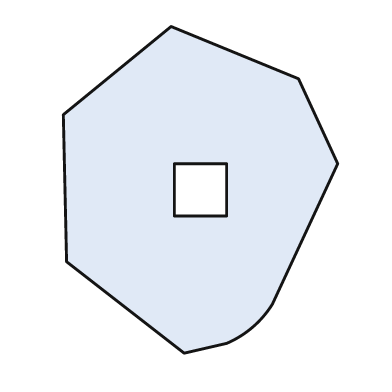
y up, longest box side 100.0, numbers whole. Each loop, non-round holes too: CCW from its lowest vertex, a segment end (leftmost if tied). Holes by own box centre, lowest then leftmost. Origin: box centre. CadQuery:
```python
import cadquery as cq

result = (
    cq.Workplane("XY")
    .moveTo(-5.0, -50.0)
    .lineTo(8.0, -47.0)
    .threePointArc((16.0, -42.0), (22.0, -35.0))
    .lineTo(42.0, 8.0)
    .lineTo(30.0, 34.0)
    .lineTo(-9.0, 50.0)
    .lineTo(-42.0, 23.0)
    .lineTo(-41.0, -22.0)
    .close()
    .moveTo(-8.0, -8.0)
    .lineTo(8.0, -8.0)
    .lineTo(8.0, 8.0)
    .lineTo(-8.0, 8.0)
    .close()
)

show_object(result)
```